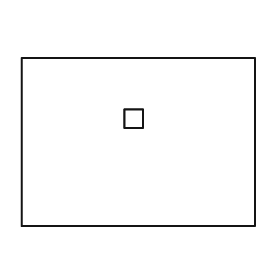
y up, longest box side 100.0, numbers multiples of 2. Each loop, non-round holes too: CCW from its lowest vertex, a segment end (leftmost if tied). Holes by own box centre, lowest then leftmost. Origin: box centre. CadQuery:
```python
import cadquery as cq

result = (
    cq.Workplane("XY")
    .moveTo(-50.0, -36.0)
    .lineTo(50.0, -36.0)
    .lineTo(50.0, 36.0)
    .lineTo(-50.0, 36.0)
    .close()
    .moveTo(-6.0, 6.0)
    .lineTo(2.0, 6.0)
    .lineTo(2.0, 14.0)
    .lineTo(-6.0, 14.0)
    .close()
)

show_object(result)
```